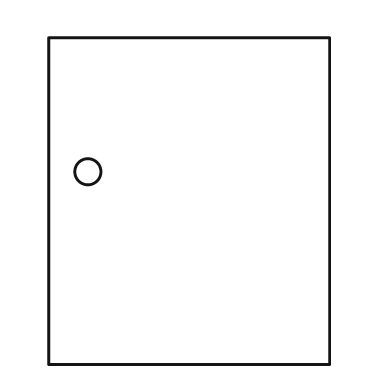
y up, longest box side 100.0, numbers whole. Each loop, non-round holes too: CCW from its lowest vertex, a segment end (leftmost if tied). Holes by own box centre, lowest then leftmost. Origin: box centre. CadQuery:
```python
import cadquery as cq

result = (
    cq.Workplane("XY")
    .moveTo(-43.0, -50.0)
    .lineTo(43.0, -50.0)
    .lineTo(43.0, 50.0)
    .lineTo(-43.0, 50.0)
    .close()
    .moveTo(-31.0, 9.0)
    .circle(4.0)
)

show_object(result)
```